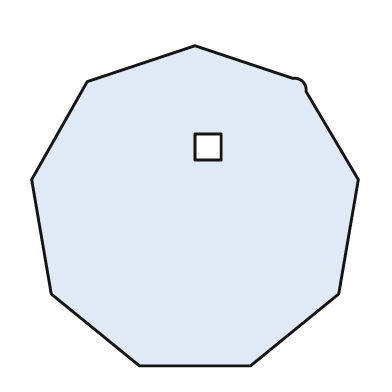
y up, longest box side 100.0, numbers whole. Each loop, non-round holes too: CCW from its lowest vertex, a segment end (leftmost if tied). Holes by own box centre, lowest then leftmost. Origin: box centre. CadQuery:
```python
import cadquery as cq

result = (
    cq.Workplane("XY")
    .moveTo(-17.0, -49.0)
    .lineTo(17.0, -49.0)
    .lineTo(44.0, -27.0)
    .lineTo(50.0, 8.0)
    .lineTo(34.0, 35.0)
    .threePointArc((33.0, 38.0), (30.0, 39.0))
    .lineTo(0.0, 49.0)
    .lineTo(-33.0, 38.0)
    .lineTo(-50.0, 8.0)
    .lineTo(-44.0, -27.0)
    .close()
    .moveTo(0.0, 14.0)
    .lineTo(8.0, 14.0)
    .lineTo(8.0, 22.0)
    .lineTo(0.0, 22.0)
    .close()
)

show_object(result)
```